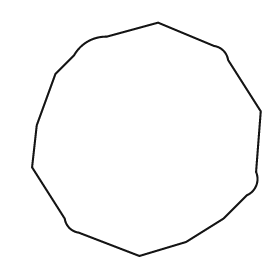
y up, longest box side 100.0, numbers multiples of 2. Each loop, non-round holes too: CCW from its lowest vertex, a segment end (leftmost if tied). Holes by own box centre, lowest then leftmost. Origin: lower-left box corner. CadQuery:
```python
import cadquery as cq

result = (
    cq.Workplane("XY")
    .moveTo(46.0, 0.0)
    .lineTo(66.0, 6.0)
    .lineTo(82.0, 16.0)
    .lineTo(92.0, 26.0)
    .threePointArc((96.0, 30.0), (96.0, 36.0))
    .lineTo(98.0, 62.0)
    .lineTo(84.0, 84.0)
    .threePointArc((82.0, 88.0), (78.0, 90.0))
    .lineTo(54.0, 100.0)
    .lineTo(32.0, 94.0)
    .threePointArc((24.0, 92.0), (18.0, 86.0))
    .lineTo(10.0, 78.0)
    .lineTo(2.0, 56.0)
    .lineTo(0.0, 38.0)
    .lineTo(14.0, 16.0)
    .threePointArc((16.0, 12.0), (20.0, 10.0))
    .close()
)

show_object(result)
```